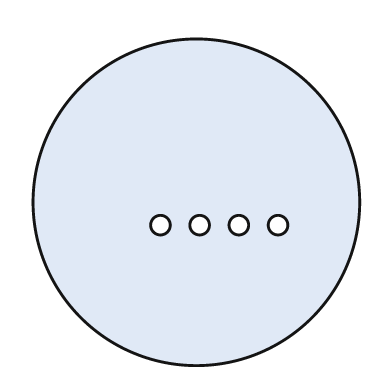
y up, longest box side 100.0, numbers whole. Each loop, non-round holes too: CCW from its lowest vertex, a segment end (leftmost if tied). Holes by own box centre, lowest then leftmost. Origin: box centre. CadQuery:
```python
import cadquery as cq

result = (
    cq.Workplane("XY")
    .moveTo(0.0, 0.0)
    .circle(50.0)
    .moveTo(-11.0, -7.0)
    .circle(3.0)
    .moveTo(1.0, -7.0)
    .circle(3.0)
    .moveTo(13.0, -7.0)
    .circle(3.0)
    .moveTo(25.0, -7.0)
    .circle(3.0)
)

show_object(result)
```